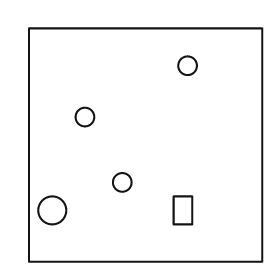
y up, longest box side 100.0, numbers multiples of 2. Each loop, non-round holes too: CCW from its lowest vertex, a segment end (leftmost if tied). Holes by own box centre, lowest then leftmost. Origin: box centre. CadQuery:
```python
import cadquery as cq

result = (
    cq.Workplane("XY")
    .moveTo(-50.0, -50.0)
    .lineTo(50.0, -50.0)
    .lineTo(50.0, 50.0)
    .lineTo(-50.0, 50.0)
    .close()
    .moveTo(-40.0, -28.0)
    .circle(6.0)
    .moveTo(12.0, -34.0)
    .lineTo(20.0, -34.0)
    .lineTo(20.0, -22.0)
    .lineTo(12.0, -22.0)
    .close()
    .moveTo(-10.0, -16.0)
    .circle(4.0)
    .moveTo(-26.0, 12.0)
    .circle(4.0)
    .moveTo(18.0, 34.0)
    .circle(4.0)
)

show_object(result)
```